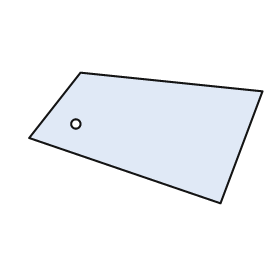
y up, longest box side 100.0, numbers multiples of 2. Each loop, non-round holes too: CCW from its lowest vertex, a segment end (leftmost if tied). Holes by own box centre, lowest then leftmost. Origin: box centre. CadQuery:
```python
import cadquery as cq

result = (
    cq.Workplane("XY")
    .moveTo(32.0, -28.0)
    .lineTo(50.0, 20.0)
    .lineTo(-28.0, 28.0)
    .lineTo(-50.0, 0.0)
    .close()
    .moveTo(-30.0, 6.0)
    .circle(2.0)
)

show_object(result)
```